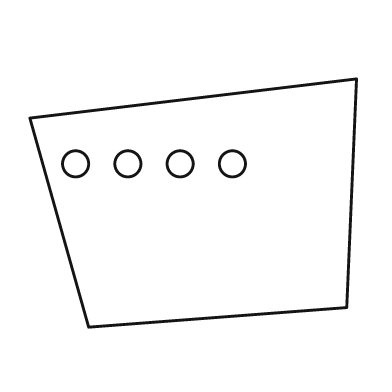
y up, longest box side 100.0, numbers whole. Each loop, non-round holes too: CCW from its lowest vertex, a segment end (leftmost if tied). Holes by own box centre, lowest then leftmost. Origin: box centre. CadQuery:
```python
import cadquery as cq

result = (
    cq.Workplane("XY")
    .moveTo(-32.0, -38.0)
    .lineTo(47.0, -32.0)
    .lineTo(50.0, 38.0)
    .lineTo(-50.0, 26.0)
    .close()
    .moveTo(-36.0, 12.0)
    .circle(4.0)
    .moveTo(-20.0, 12.0)
    .circle(4.0)
    .moveTo(-4.0, 12.0)
    .circle(4.0)
    .moveTo(12.0, 12.0)
    .circle(4.0)
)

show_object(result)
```